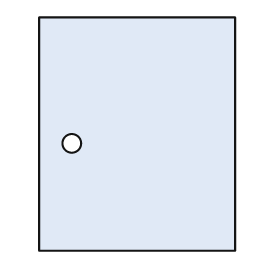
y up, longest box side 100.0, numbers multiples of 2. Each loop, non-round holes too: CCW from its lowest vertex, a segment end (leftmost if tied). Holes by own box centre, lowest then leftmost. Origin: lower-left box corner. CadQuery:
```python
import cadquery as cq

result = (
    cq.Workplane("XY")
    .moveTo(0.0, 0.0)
    .lineTo(84.0, 0.0)
    .lineTo(84.0, 100.0)
    .lineTo(0.0, 100.0)
    .close()
    .moveTo(14.0, 46.0)
    .circle(4.0)
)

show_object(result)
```